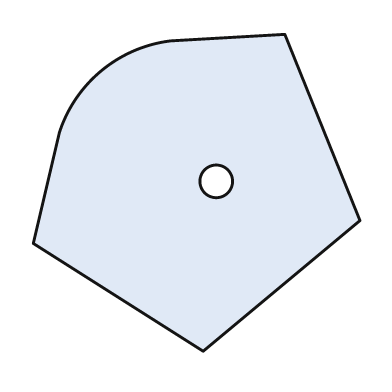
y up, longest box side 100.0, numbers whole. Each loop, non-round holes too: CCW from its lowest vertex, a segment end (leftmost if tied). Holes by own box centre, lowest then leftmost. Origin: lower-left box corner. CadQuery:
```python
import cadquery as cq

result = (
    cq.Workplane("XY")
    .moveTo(52.0, 0.0)
    .lineTo(100.0, 40.0)
    .lineTo(77.0, 97.0)
    .lineTo(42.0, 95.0)
    .threePointArc((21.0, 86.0), (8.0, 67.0))
    .lineTo(0.0, 33.0)
    .close()
    .moveTo(56.0, 52.0)
    .circle(5.0)
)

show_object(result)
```